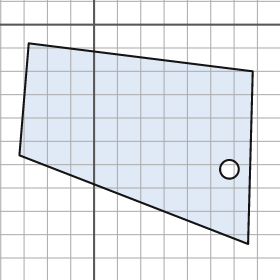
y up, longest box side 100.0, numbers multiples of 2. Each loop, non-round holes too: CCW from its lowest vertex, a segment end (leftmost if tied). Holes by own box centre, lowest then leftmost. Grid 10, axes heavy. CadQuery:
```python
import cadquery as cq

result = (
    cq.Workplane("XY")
    .moveTo(66.0, -94.0)
    .lineTo(68.0, -20.0)
    .lineTo(-28.0, -8.0)
    .lineTo(-32.0, -56.0)
    .close()
    .moveTo(58.0, -62.0)
    .circle(4.0)
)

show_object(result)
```